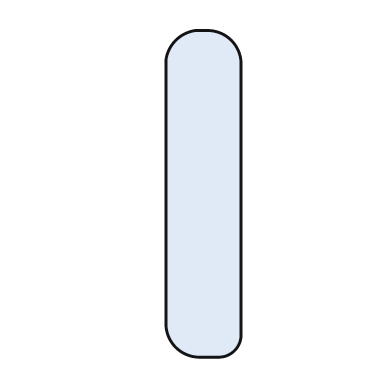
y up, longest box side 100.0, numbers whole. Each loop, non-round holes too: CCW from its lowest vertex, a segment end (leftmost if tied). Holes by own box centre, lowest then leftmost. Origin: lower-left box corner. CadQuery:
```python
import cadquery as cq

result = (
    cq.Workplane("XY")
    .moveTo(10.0, 0.0)
    .lineTo(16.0, 0.0)
    .threePointArc((21.0, 2.0), (23.0, 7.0))
    .lineTo(23.0, 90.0)
    .threePointArc((20.0, 97.0), (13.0, 100.0))
    .lineTo(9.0, 100.0)
    .threePointArc((3.0, 97.0), (0.0, 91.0))
    .lineTo(0.0, 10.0)
    .threePointArc((3.0, 3.0), (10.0, 0.0))
    .close()
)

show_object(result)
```